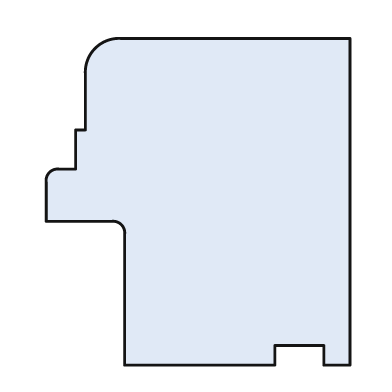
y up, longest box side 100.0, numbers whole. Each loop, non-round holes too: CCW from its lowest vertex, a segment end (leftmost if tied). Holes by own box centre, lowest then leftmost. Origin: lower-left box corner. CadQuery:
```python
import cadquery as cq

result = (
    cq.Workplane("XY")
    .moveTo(24.0, 0.0)
    .lineTo(70.0, 0.0)
    .lineTo(70.0, 6.0)
    .lineTo(85.0, 6.0)
    .lineTo(85.0, 0.0)
    .lineTo(93.0, 0.0)
    .lineTo(93.0, 100.0)
    .lineTo(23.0, 100.0)
    .threePointArc((15.0, 97.0), (12.0, 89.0))
    .lineTo(12.0, 72.0)
    .lineTo(9.0, 72.0)
    .lineTo(9.0, 60.0)
    .lineTo(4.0, 60.0)
    .threePointArc((1.0, 59.0), (0.0, 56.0))
    .lineTo(0.0, 44.0)
    .lineTo(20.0, 44.0)
    .threePointArc((23.0, 43.0), (24.0, 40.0))
    .close()
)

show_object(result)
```